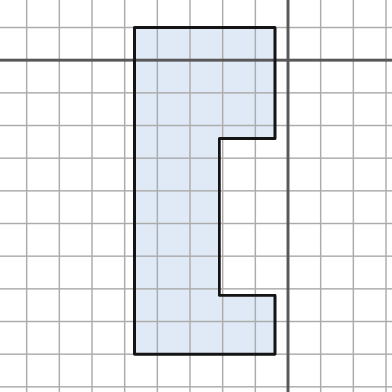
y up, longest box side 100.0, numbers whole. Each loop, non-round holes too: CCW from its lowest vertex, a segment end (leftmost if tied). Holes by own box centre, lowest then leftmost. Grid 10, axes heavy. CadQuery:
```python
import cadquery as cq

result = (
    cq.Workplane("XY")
    .moveTo(-47.0, -90.0)
    .lineTo(-4.0, -90.0)
    .lineTo(-4.0, -72.0)
    .lineTo(-21.0, -72.0)
    .lineTo(-21.0, -24.0)
    .lineTo(-4.0, -24.0)
    .lineTo(-4.0, 10.0)
    .lineTo(-47.0, 10.0)
    .close()
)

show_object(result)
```